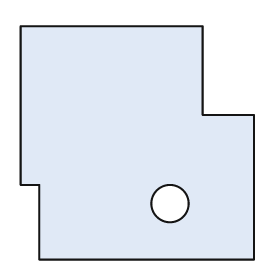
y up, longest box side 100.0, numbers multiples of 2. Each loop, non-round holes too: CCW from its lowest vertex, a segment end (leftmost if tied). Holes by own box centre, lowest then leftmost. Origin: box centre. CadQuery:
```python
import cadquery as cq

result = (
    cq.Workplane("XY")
    .moveTo(-42.0, -50.0)
    .lineTo(50.0, -50.0)
    .lineTo(50.0, 12.0)
    .lineTo(28.0, 12.0)
    .lineTo(28.0, 50.0)
    .lineTo(-50.0, 50.0)
    .lineTo(-50.0, -18.0)
    .lineTo(-42.0, -18.0)
    .close()
    .moveTo(14.0, -26.0)
    .circle(8.0)
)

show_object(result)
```